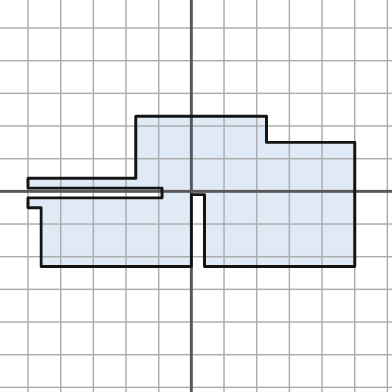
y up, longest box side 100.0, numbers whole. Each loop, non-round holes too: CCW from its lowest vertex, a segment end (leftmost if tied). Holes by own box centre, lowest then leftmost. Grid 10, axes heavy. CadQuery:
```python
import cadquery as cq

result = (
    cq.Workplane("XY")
    .moveTo(-46.0, -23.0)
    .lineTo(0.0, -23.0)
    .lineTo(0.0, -1.0)
    .lineTo(4.0, -1.0)
    .lineTo(4.0, -23.0)
    .lineTo(50.0, -23.0)
    .lineTo(50.0, 15.0)
    .lineTo(23.0, 15.0)
    .lineTo(23.0, 23.0)
    .lineTo(-17.0, 23.0)
    .lineTo(-17.0, 4.0)
    .lineTo(-50.0, 4.0)
    .lineTo(-50.0, 1.0)
    .lineTo(-9.0, 1.0)
    .lineTo(-9.0, -2.0)
    .lineTo(-50.0, -2.0)
    .lineTo(-50.0, -5.0)
    .lineTo(-46.0, -5.0)
    .close()
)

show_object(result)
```